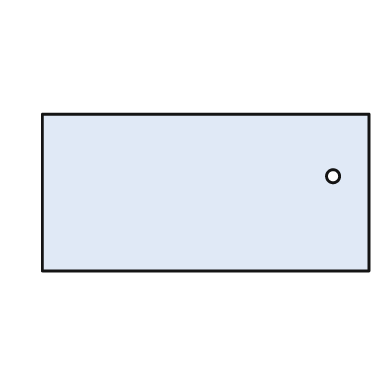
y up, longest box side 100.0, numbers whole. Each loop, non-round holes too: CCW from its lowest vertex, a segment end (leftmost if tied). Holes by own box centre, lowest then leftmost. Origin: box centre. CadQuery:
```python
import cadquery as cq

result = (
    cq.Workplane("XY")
    .moveTo(-50.0, -24.0)
    .lineTo(50.0, -24.0)
    .lineTo(50.0, 24.0)
    .lineTo(-50.0, 24.0)
    .close()
    .moveTo(39.0, 5.0)
    .circle(2.0)
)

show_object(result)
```